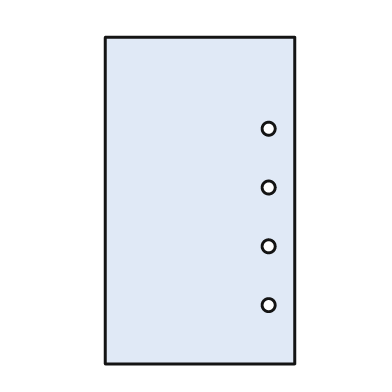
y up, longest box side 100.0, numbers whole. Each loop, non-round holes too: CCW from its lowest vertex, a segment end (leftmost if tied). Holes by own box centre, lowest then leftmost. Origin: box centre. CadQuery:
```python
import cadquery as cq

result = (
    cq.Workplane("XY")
    .moveTo(-29.0, -50.0)
    .lineTo(29.0, -50.0)
    .lineTo(29.0, 50.0)
    .lineTo(-29.0, 50.0)
    .close()
    .moveTo(21.0, -32.0)
    .circle(2.0)
    .moveTo(21.0, -14.0)
    .circle(2.0)
    .moveTo(21.0, 4.0)
    .circle(2.0)
    .moveTo(21.0, 22.0)
    .circle(2.0)
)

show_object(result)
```